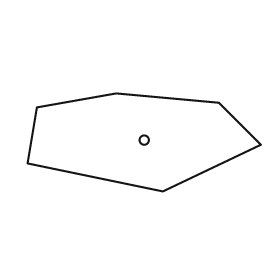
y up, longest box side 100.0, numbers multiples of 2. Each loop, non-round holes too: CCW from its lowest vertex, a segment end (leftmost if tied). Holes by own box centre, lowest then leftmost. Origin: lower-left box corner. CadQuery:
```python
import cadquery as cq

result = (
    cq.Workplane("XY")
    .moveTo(58.0, 0.0)
    .lineTo(100.0, 20.0)
    .lineTo(82.0, 38.0)
    .lineTo(38.0, 42.0)
    .lineTo(4.0, 36.0)
    .lineTo(0.0, 12.0)
    .close()
    .moveTo(50.0, 22.0)
    .circle(2.0)
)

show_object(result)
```